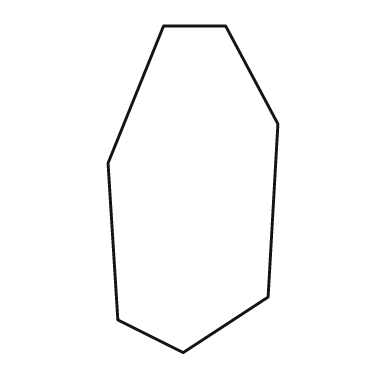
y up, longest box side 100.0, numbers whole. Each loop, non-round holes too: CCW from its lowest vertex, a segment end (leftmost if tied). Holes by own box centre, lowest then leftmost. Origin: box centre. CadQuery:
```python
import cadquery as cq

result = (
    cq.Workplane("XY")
    .moveTo(-3.0, -50.0)
    .lineTo(23.0, -33.0)
    .lineTo(26.0, 20.0)
    .lineTo(10.0, 50.0)
    .lineTo(-9.0, 50.0)
    .lineTo(-26.0, 8.0)
    .lineTo(-23.0, -40.0)
    .close()
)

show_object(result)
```